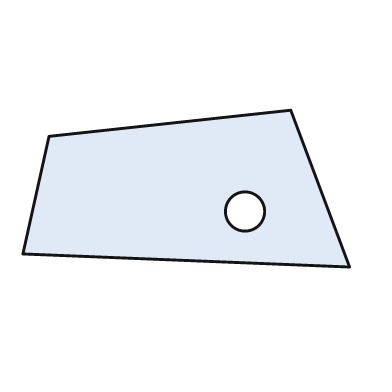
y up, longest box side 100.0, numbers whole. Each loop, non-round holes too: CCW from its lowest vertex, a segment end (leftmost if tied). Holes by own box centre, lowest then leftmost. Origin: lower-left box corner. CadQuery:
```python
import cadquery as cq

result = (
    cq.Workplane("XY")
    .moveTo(100.0, 0.0)
    .lineTo(82.0, 48.0)
    .lineTo(8.0, 40.0)
    .lineTo(0.0, 4.0)
    .close()
    .moveTo(68.0, 17.0)
    .circle(6.0)
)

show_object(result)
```